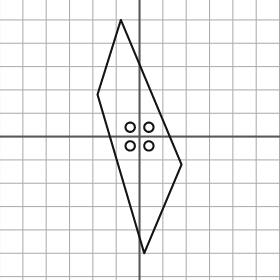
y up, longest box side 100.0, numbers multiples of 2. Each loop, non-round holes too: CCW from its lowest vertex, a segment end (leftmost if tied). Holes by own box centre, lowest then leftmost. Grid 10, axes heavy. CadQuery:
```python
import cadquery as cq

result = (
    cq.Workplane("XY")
    .moveTo(2.0, -50.0)
    .lineTo(18.0, -12.0)
    .lineTo(-8.0, 50.0)
    .lineTo(-18.0, 18.0)
    .close()
    .moveTo(-4.0, -4.0)
    .circle(2.0)
    .moveTo(4.0, -4.0)
    .circle(2.0)
    .moveTo(-4.0, 4.0)
    .circle(2.0)
    .moveTo(4.0, 4.0)
    .circle(2.0)
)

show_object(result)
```